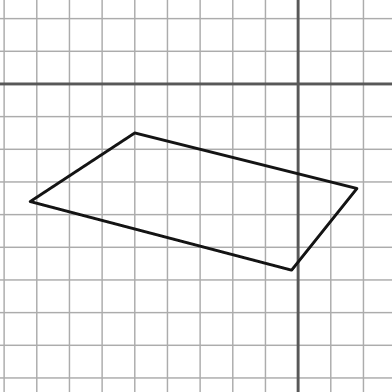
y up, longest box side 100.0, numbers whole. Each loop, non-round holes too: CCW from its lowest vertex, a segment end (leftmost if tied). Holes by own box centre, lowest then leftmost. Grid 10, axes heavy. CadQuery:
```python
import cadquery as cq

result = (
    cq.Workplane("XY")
    .moveTo(-2.0, -57.0)
    .lineTo(18.0, -32.0)
    .lineTo(-50.0, -15.0)
    .lineTo(-82.0, -36.0)
    .close()
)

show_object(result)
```